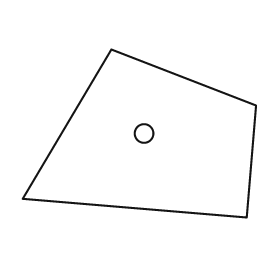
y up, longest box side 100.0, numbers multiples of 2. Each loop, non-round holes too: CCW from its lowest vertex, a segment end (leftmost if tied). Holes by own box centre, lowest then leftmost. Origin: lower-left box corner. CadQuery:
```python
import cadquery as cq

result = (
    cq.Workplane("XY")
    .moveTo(96.0, 0.0)
    .lineTo(100.0, 48.0)
    .lineTo(38.0, 72.0)
    .lineTo(0.0, 8.0)
    .close()
    .moveTo(52.0, 36.0)
    .circle(4.0)
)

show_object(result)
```